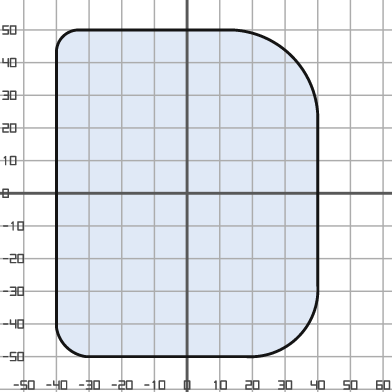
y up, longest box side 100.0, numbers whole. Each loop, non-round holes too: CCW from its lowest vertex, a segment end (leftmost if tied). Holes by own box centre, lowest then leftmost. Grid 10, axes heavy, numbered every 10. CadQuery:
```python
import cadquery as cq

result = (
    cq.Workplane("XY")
    .moveTo(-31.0, -50.0)
    .lineTo(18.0, -50.0)
    .threePointArc((34.0, -44.0), (40.0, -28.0))
    .lineTo(40.0, 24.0)
    .threePointArc((32.0, 42.0), (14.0, 50.0))
    .lineTo(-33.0, 50.0)
    .threePointArc((-38.0, 48.0), (-40.0, 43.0))
    .lineTo(-40.0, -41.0)
    .threePointArc((-37.0, -47.0), (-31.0, -50.0))
    .close()
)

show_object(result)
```